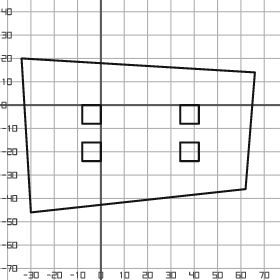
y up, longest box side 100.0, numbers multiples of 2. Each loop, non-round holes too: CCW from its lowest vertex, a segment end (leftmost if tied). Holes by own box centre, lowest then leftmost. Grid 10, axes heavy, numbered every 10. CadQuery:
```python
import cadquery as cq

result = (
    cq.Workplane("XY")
    .moveTo(-30.0, -46.0)
    .lineTo(62.0, -36.0)
    .lineTo(66.0, 14.0)
    .lineTo(-34.0, 20.0)
    .close()
    .moveTo(-8.0, -24.0)
    .lineTo(0.0, -24.0)
    .lineTo(0.0, -16.0)
    .lineTo(-8.0, -16.0)
    .close()
    .moveTo(34.0, -24.0)
    .lineTo(42.0, -24.0)
    .lineTo(42.0, -16.0)
    .lineTo(34.0, -16.0)
    .close()
    .moveTo(-8.0, -8.0)
    .lineTo(0.0, -8.0)
    .lineTo(0.0, 0.0)
    .lineTo(-8.0, 0.0)
    .close()
    .moveTo(34.0, -8.0)
    .lineTo(42.0, -8.0)
    .lineTo(42.0, 0.0)
    .lineTo(34.0, 0.0)
    .close()
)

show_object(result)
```